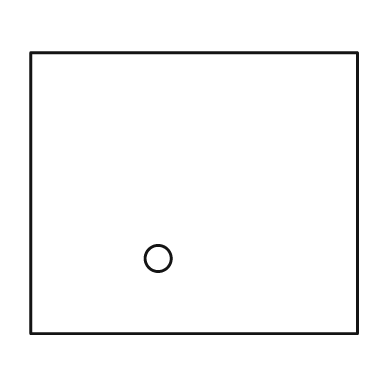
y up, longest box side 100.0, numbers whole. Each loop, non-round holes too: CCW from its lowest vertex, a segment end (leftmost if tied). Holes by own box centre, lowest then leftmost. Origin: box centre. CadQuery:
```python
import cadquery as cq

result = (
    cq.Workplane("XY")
    .moveTo(-50.0, -43.0)
    .lineTo(50.0, -43.0)
    .lineTo(50.0, 43.0)
    .lineTo(-50.0, 43.0)
    .close()
    .moveTo(-11.0, -20.0)
    .circle(4.0)
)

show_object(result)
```